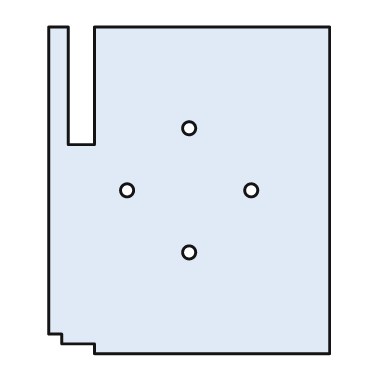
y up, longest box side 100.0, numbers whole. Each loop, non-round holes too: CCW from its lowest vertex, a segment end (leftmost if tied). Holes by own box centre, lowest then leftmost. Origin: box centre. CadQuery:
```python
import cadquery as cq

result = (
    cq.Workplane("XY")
    .moveTo(-29.0, -50.0)
    .lineTo(43.0, -50.0)
    .lineTo(43.0, 50.0)
    .lineTo(-29.0, 50.0)
    .lineTo(-29.0, 14.0)
    .lineTo(-37.0, 14.0)
    .lineTo(-37.0, 50.0)
    .lineTo(-43.0, 50.0)
    .lineTo(-43.0, -44.0)
    .lineTo(-39.0, -44.0)
    .lineTo(-39.0, -47.0)
    .lineTo(-29.0, -47.0)
    .close()
    .moveTo(0.0, -19.0)
    .circle(2.0)
    .moveTo(-19.0, 0.0)
    .circle(2.0)
    .moveTo(19.0, 0.0)
    .circle(2.0)
    .moveTo(0.0, 19.0)
    .circle(2.0)
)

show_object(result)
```